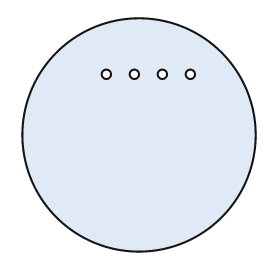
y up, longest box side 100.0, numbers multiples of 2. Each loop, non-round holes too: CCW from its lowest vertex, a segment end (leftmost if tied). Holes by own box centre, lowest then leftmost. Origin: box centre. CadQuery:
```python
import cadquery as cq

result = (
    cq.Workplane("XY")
    .moveTo(0.0, 0.0)
    .circle(50.0)
    .moveTo(-14.0, 26.0)
    .circle(2.0)
    .moveTo(-2.0, 26.0)
    .circle(2.0)
    .moveTo(10.0, 26.0)
    .circle(2.0)
    .moveTo(22.0, 26.0)
    .circle(2.0)
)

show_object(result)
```